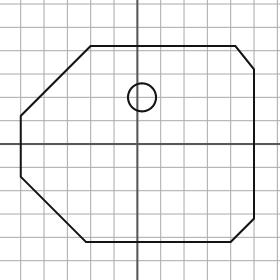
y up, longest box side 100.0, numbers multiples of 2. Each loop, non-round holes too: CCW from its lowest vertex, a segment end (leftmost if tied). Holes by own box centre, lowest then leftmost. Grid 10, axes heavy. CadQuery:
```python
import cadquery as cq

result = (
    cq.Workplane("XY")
    .moveTo(-22.0, -42.0)
    .lineTo(40.0, -42.0)
    .lineTo(50.0, -32.0)
    .lineTo(50.0, 32.0)
    .lineTo(42.0, 42.0)
    .lineTo(-20.0, 42.0)
    .lineTo(-50.0, 12.0)
    .lineTo(-50.0, -14.0)
    .close()
    .moveTo(2.0, 20.0)
    .circle(6.0)
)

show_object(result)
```